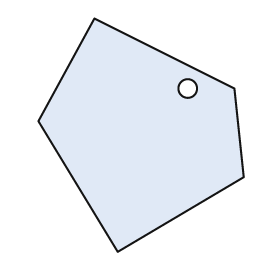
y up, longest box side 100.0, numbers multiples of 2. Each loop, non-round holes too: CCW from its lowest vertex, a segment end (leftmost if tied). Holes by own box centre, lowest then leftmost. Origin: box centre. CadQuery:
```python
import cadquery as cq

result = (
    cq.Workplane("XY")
    .moveTo(-10.0, -50.0)
    .lineTo(44.0, -18.0)
    .lineTo(40.0, 20.0)
    .lineTo(-20.0, 50.0)
    .lineTo(-44.0, 6.0)
    .close()
    .moveTo(20.0, 20.0)
    .circle(4.0)
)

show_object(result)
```